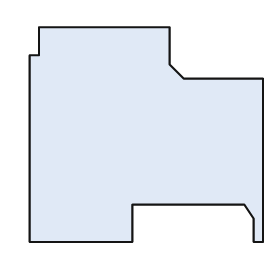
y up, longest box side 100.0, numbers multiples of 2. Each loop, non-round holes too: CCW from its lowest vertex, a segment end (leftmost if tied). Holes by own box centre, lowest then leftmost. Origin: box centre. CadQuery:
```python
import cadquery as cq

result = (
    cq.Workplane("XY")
    .moveTo(-50.0, -46.0)
    .lineTo(-6.0, -46.0)
    .lineTo(-6.0, -30.0)
    .lineTo(42.0, -30.0)
    .lineTo(46.0, -36.0)
    .lineTo(46.0, -46.0)
    .lineTo(50.0, -46.0)
    .lineTo(50.0, 24.0)
    .lineTo(16.0, 24.0)
    .lineTo(10.0, 30.0)
    .lineTo(10.0, 46.0)
    .lineTo(-46.0, 46.0)
    .lineTo(-46.0, 34.0)
    .lineTo(-50.0, 34.0)
    .close()
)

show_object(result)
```